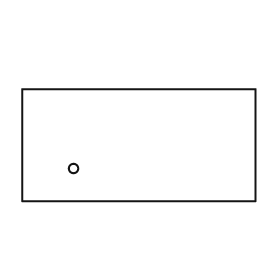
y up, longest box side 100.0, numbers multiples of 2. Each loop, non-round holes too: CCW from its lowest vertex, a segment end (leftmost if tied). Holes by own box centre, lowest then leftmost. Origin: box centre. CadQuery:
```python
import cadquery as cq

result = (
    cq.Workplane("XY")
    .moveTo(-50.0, -24.0)
    .lineTo(50.0, -24.0)
    .lineTo(50.0, 24.0)
    .lineTo(-50.0, 24.0)
    .close()
    .moveTo(-28.0, -10.0)
    .circle(2.0)
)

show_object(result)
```